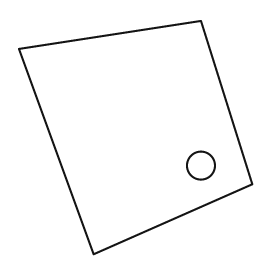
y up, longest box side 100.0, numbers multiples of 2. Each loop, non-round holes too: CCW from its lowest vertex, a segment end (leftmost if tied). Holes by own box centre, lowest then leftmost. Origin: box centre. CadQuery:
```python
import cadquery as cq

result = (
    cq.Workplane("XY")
    .moveTo(-18.0, -50.0)
    .lineTo(50.0, -20.0)
    .lineTo(28.0, 50.0)
    .lineTo(-50.0, 38.0)
    .close()
    .moveTo(28.0, -12.0)
    .circle(6.0)
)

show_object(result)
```